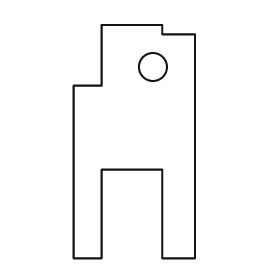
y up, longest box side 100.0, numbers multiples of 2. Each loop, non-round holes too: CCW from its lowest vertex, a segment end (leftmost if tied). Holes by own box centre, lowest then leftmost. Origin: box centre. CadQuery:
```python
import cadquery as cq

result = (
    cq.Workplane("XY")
    .moveTo(-26.0, -50.0)
    .lineTo(-14.0, -50.0)
    .lineTo(-14.0, -12.0)
    .lineTo(12.0, -12.0)
    .lineTo(12.0, -50.0)
    .lineTo(26.0, -50.0)
    .lineTo(26.0, 46.0)
    .lineTo(12.0, 46.0)
    .lineTo(12.0, 50.0)
    .lineTo(-14.0, 50.0)
    .lineTo(-14.0, 24.0)
    .lineTo(-26.0, 24.0)
    .close()
    .moveTo(8.0, 32.0)
    .circle(6.0)
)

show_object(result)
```